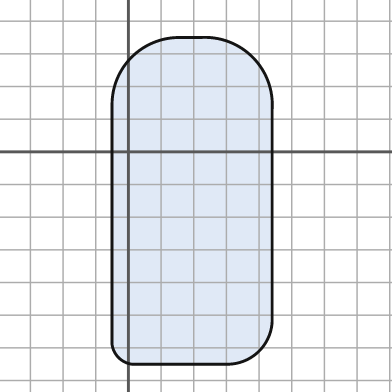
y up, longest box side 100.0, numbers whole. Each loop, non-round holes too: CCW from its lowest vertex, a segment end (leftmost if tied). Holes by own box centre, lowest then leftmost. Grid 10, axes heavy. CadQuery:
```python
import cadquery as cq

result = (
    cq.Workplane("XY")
    .moveTo(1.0, -65.0)
    .lineTo(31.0, -65.0)
    .threePointArc((40.0, -61.0), (44.0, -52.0))
    .lineTo(44.0, 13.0)
    .threePointArc((38.0, 29.0), (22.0, 35.0))
    .lineTo(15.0, 35.0)
    .threePointArc((1.0, 29.0), (-5.0, 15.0))
    .lineTo(-5.0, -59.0)
    .threePointArc((-3.0, -63.0), (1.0, -65.0))
    .close()
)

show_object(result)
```